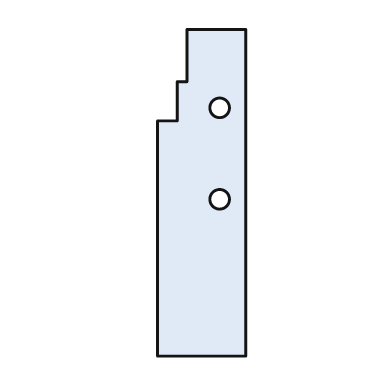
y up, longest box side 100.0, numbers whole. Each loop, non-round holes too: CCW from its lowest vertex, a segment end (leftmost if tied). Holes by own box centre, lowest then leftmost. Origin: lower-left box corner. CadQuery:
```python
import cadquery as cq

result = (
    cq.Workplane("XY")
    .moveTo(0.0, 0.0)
    .lineTo(27.0, 0.0)
    .lineTo(27.0, 100.0)
    .lineTo(9.0, 100.0)
    .lineTo(9.0, 84.0)
    .lineTo(6.0, 84.0)
    .lineTo(6.0, 72.0)
    .lineTo(0.0, 72.0)
    .close()
    .moveTo(19.0, 48.0)
    .circle(3.0)
    .moveTo(19.0, 76.0)
    .circle(3.0)
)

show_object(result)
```